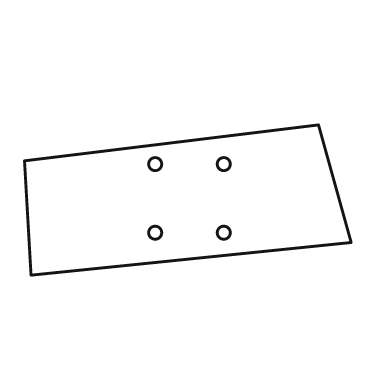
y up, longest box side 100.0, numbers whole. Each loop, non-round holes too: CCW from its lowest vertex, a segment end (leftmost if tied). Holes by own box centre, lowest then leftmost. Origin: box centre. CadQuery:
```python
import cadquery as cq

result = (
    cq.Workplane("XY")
    .moveTo(-48.0, -23.0)
    .lineTo(50.0, -13.0)
    .lineTo(40.0, 23.0)
    .lineTo(-50.0, 12.0)
    .close()
    .moveTo(-10.0, -10.0)
    .circle(2.0)
    .moveTo(11.0, -10.0)
    .circle(2.0)
    .moveTo(-10.0, 11.0)
    .circle(2.0)
    .moveTo(11.0, 11.0)
    .circle(2.0)
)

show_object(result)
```